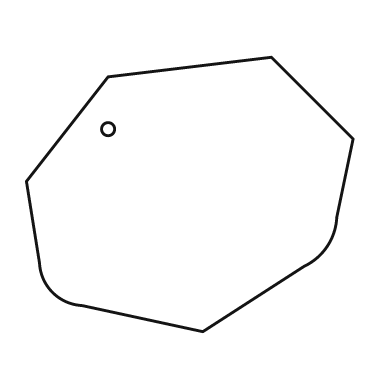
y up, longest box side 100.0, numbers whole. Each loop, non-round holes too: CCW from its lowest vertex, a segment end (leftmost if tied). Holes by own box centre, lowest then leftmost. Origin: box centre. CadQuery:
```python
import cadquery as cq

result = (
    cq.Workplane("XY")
    .moveTo(4.0, -42.0)
    .lineTo(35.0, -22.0)
    .threePointArc((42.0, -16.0), (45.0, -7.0))
    .lineTo(50.0, 17.0)
    .lineTo(25.0, 42.0)
    .lineTo(-25.0, 36.0)
    .lineTo(-50.0, 4.0)
    .lineTo(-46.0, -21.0)
    .threePointArc((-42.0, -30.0), (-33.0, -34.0))
    .close()
    .moveTo(-25.0, 20.0)
    .circle(2.0)
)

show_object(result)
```